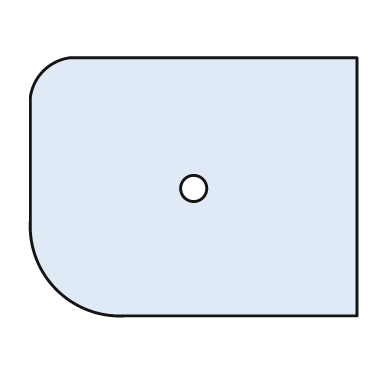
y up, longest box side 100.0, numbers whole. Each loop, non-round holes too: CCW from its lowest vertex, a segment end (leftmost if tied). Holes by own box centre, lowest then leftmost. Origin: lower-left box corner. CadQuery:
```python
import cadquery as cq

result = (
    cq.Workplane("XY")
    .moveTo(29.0, 0.0)
    .lineTo(100.0, 0.0)
    .lineTo(100.0, 79.0)
    .lineTo(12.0, 79.0)
    .threePointArc((4.0, 75.0), (0.0, 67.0))
    .lineTo(0.0, 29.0)
    .threePointArc((8.0, 8.0), (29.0, 0.0))
    .close()
    .moveTo(50.0, 39.0)
    .circle(4.0)
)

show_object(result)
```